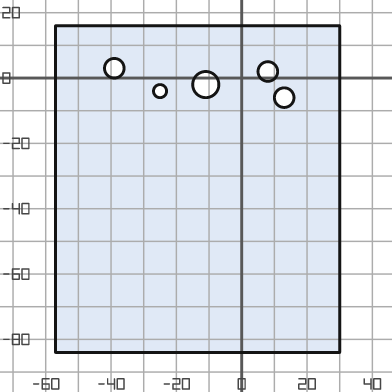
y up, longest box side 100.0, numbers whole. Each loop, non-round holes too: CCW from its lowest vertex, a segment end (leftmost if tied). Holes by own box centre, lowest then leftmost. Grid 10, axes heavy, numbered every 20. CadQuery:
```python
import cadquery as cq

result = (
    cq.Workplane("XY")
    .moveTo(-57.0, -84.0)
    .lineTo(30.0, -84.0)
    .lineTo(30.0, 16.0)
    .lineTo(-57.0, 16.0)
    .close()
    .moveTo(13.0, -6.0)
    .circle(3.0)
    .moveTo(-25.0, -4.0)
    .circle(2.0)
    .moveTo(-11.0, -2.0)
    .circle(4.0)
    .moveTo(8.0, 2.0)
    .circle(3.0)
    .moveTo(-39.0, 3.0)
    .circle(3.0)
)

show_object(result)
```